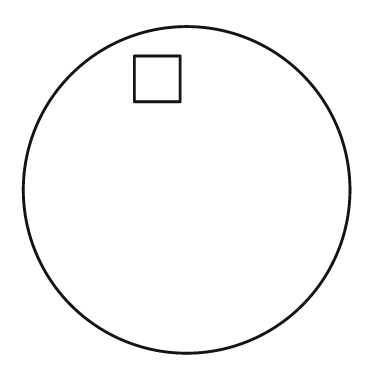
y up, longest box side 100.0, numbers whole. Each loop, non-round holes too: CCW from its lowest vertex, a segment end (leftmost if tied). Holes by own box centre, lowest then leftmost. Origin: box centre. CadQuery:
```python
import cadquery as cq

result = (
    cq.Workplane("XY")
    .moveTo(0.0, 0.0)
    .circle(50.0)
    .moveTo(-16.0, 27.0)
    .lineTo(-2.0, 27.0)
    .lineTo(-2.0, 41.0)
    .lineTo(-16.0, 41.0)
    .close()
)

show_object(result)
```